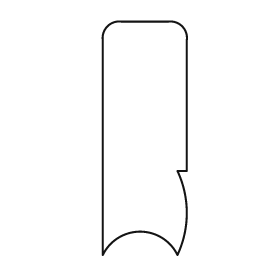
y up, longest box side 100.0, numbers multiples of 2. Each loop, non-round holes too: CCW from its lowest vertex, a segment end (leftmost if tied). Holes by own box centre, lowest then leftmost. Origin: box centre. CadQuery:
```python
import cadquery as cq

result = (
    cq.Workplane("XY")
    .moveTo(-18.0, -50.0)
    .threePointArc((-2.0, -40.0), (14.0, -50.0))
    .threePointArc((18.0, -32.0), (14.0, -14.0))
    .lineTo(18.0, -14.0)
    .lineTo(18.0, 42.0)
    .threePointArc((16.0, 48.0), (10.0, 50.0))
    .lineTo(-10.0, 50.0)
    .threePointArc((-16.0, 48.0), (-18.0, 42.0))
    .close()
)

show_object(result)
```